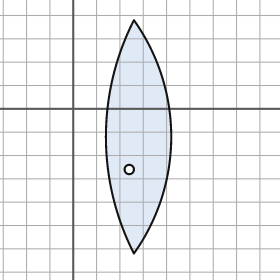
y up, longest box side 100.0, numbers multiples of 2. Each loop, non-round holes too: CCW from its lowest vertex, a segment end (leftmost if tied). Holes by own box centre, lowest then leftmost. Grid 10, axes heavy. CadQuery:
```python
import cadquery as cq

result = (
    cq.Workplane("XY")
    .moveTo(26.0, -62.0)
    .threePointArc((42.0, -12.0), (26.0, 38.0))
    .threePointArc((14.0, -12.0), (26.0, -62.0))
    .close()
    .moveTo(24.0, -26.0)
    .circle(2.0)
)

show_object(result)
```